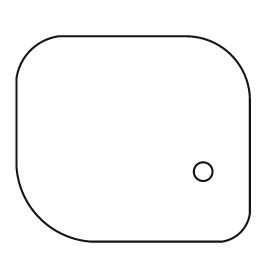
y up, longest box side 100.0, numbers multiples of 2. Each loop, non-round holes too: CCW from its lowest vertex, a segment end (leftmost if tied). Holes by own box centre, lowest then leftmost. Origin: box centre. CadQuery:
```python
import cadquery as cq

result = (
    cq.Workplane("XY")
    .moveTo(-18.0, -44.0)
    .lineTo(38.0, -44.0)
    .threePointArc((46.0, -40.0), (50.0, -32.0))
    .lineTo(50.0, 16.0)
    .threePointArc((42.0, 36.0), (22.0, 44.0))
    .lineTo(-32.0, 44.0)
    .threePointArc((-44.0, 38.0), (-50.0, 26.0))
    .lineTo(-50.0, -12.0)
    .threePointArc((-40.0, -34.0), (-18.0, -44.0))
    .close()
    .moveTo(30.0, -14.0)
    .circle(4.0)
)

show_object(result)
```